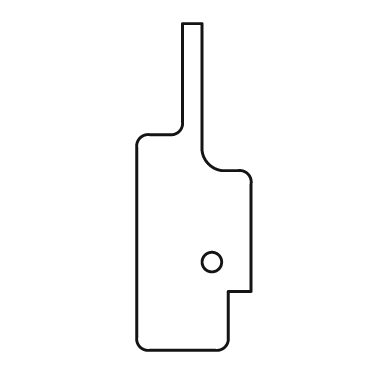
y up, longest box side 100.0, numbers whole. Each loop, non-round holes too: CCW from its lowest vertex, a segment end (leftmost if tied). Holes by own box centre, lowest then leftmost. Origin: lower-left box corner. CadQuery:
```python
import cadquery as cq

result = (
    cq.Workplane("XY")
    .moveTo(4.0, 0.0)
    .lineTo(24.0, 0.0)
    .threePointArc((27.0, 1.0), (28.0, 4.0))
    .lineTo(28.0, 18.0)
    .lineTo(35.0, 18.0)
    .lineTo(35.0, 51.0)
    .threePointArc((34.0, 54.0), (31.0, 55.0))
    .lineTo(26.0, 55.0)
    .threePointArc((22.0, 57.0), (20.0, 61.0))
    .lineTo(20.0, 100.0)
    .lineTo(14.0, 100.0)
    .lineTo(14.0, 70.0)
    .threePointArc((13.0, 67.0), (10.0, 66.0))
    .lineTo(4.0, 66.0)
    .threePointArc((1.0, 65.0), (0.0, 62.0))
    .lineTo(0.0, 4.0)
    .threePointArc((1.0, 1.0), (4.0, 0.0))
    .close()
    .moveTo(23.0, 27.0)
    .circle(3.0)
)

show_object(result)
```